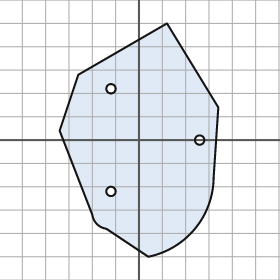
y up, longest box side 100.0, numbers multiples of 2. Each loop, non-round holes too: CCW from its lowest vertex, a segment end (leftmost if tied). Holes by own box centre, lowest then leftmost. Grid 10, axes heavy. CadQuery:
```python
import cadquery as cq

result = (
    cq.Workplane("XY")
    .moveTo(4.0, -50.0)
    .threePointArc((24.0, -38.0), (32.0, -16.0))
    .lineTo(34.0, 14.0)
    .lineTo(12.0, 50.0)
    .lineTo(-26.0, 28.0)
    .lineTo(-34.0, 4.0)
    .lineTo(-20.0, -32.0)
    .threePointArc((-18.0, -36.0), (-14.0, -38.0))
    .close()
    .moveTo(-12.0, -22.0)
    .circle(2.0)
    .moveTo(26.0, 0.0)
    .circle(2.0)
    .moveTo(-12.0, 22.0)
    .circle(2.0)
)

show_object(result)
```